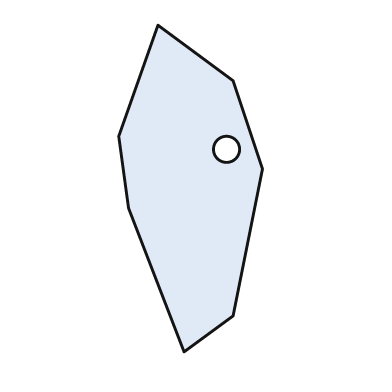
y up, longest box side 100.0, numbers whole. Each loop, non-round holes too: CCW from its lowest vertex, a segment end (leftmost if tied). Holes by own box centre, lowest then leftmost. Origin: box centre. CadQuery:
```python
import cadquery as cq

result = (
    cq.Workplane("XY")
    .moveTo(-2.0, -50.0)
    .lineTo(13.0, -39.0)
    .lineTo(22.0, 6.0)
    .lineTo(13.0, 33.0)
    .lineTo(-10.0, 50.0)
    .lineTo(-22.0, 16.0)
    .lineTo(-19.0, -6.0)
    .close()
    .moveTo(11.0, 12.0)
    .circle(4.0)
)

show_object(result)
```